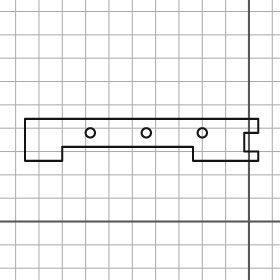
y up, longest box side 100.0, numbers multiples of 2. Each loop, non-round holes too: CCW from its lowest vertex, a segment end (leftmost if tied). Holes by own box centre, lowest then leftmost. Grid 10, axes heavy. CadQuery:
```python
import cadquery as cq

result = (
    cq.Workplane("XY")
    .moveTo(-96.0, 26.0)
    .lineTo(-80.0, 26.0)
    .lineTo(-80.0, 32.0)
    .lineTo(-24.0, 32.0)
    .lineTo(-24.0, 26.0)
    .lineTo(4.0, 26.0)
    .lineTo(4.0, 30.0)
    .lineTo(-2.0, 30.0)
    .lineTo(-2.0, 38.0)
    .lineTo(4.0, 38.0)
    .lineTo(4.0, 44.0)
    .lineTo(-96.0, 44.0)
    .close()
    .moveTo(-68.0, 38.0)
    .circle(2.0)
    .moveTo(-44.0, 38.0)
    .circle(2.0)
    .moveTo(-20.0, 38.0)
    .circle(2.0)
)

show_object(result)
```